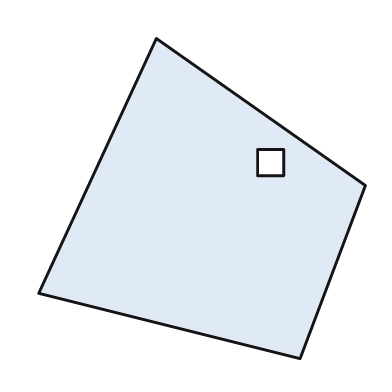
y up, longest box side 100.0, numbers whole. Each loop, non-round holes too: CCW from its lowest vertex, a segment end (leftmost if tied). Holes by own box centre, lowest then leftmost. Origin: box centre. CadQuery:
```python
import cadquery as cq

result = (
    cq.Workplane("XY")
    .moveTo(30.0, -49.0)
    .lineTo(50.0, 4.0)
    .lineTo(-14.0, 49.0)
    .lineTo(-50.0, -29.0)
    .close()
    .moveTo(17.0, 7.0)
    .lineTo(25.0, 7.0)
    .lineTo(25.0, 15.0)
    .lineTo(17.0, 15.0)
    .close()
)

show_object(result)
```